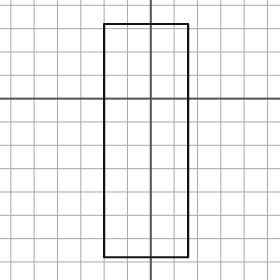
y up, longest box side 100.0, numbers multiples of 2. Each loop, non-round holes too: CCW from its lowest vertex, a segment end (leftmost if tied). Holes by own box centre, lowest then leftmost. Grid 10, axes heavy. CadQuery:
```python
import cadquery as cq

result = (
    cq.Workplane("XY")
    .moveTo(-20.0, -68.0)
    .lineTo(16.0, -68.0)
    .lineTo(16.0, 32.0)
    .lineTo(-20.0, 32.0)
    .close()
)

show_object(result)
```